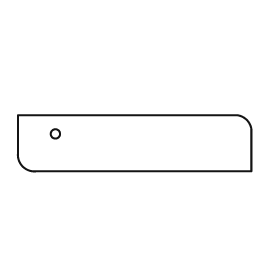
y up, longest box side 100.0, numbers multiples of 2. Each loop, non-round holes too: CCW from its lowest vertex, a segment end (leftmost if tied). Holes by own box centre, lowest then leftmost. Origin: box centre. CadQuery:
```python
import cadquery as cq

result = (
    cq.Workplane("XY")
    .moveTo(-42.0, -12.0)
    .lineTo(50.0, -12.0)
    .lineTo(50.0, 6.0)
    .threePointArc((48.0, 10.0), (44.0, 12.0))
    .lineTo(-50.0, 12.0)
    .lineTo(-50.0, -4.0)
    .threePointArc((-48.0, -10.0), (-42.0, -12.0))
    .close()
    .moveTo(-34.0, 4.0)
    .circle(2.0)
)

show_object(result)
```